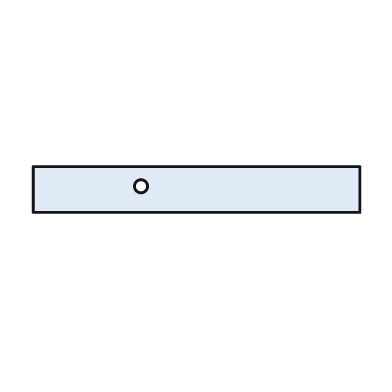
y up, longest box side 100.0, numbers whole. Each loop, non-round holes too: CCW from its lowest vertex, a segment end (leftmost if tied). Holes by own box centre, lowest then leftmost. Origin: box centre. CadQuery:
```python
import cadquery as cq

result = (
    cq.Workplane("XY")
    .moveTo(-50.0, -7.0)
    .lineTo(50.0, -7.0)
    .lineTo(50.0, 7.0)
    .lineTo(-50.0, 7.0)
    .close()
    .moveTo(-17.0, 1.0)
    .circle(2.0)
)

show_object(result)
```